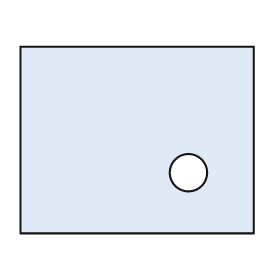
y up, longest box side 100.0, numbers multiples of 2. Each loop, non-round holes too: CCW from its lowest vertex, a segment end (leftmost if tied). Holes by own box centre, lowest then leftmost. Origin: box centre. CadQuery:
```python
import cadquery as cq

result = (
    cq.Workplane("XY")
    .moveTo(-50.0, -40.0)
    .lineTo(50.0, -40.0)
    .lineTo(50.0, 40.0)
    .lineTo(-50.0, 40.0)
    .close()
    .moveTo(22.0, -14.0)
    .circle(8.0)
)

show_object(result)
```